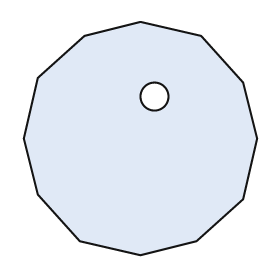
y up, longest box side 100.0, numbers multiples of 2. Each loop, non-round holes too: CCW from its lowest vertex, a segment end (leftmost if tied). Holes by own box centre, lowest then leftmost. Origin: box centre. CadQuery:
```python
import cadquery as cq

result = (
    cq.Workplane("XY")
    .moveTo(0.0, -50.0)
    .lineTo(24.0, -44.0)
    .lineTo(44.0, -26.0)
    .lineTo(50.0, 0.0)
    .lineTo(44.0, 24.0)
    .lineTo(26.0, 44.0)
    .lineTo(0.0, 50.0)
    .lineTo(-24.0, 44.0)
    .lineTo(-44.0, 26.0)
    .lineTo(-50.0, 0.0)
    .lineTo(-44.0, -24.0)
    .lineTo(-26.0, -44.0)
    .close()
    .moveTo(6.0, 18.0)
    .circle(6.0)
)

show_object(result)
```